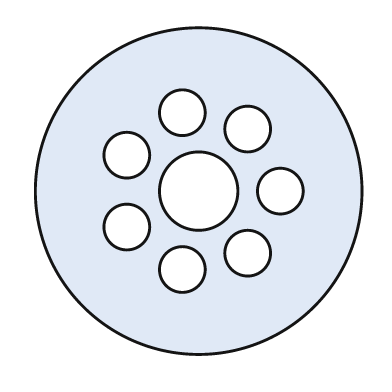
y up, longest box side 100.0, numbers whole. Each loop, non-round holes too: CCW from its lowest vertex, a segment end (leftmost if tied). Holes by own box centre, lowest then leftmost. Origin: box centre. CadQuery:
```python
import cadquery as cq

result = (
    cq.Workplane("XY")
    .moveTo(0.0, 0.0)
    .circle(50.0)
    .moveTo(-5.0, -24.0)
    .circle(7.0)
    .moveTo(15.0, -19.0)
    .circle(7.0)
    .moveTo(-22.0, -11.0)
    .circle(7.0)
    .moveTo(0.0, 0.0)
    .circle(12.0)
    .moveTo(25.0, 0.0)
    .circle(7.0)
    .moveTo(-22.0, 11.0)
    .circle(7.0)
    .moveTo(15.0, 19.0)
    .circle(7.0)
    .moveTo(-5.0, 24.0)
    .circle(7.0)
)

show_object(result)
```